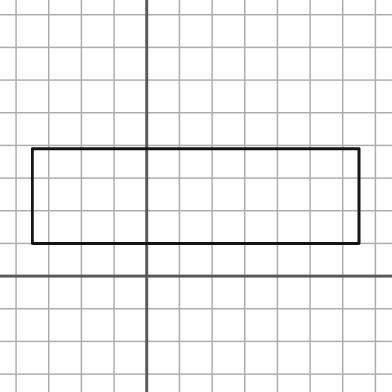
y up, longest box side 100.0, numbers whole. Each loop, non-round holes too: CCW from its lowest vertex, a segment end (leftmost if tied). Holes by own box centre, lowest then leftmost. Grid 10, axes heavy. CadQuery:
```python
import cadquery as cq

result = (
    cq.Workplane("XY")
    .moveTo(-35.0, 10.0)
    .lineTo(65.0, 10.0)
    .lineTo(65.0, 39.0)
    .lineTo(-35.0, 39.0)
    .close()
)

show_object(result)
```